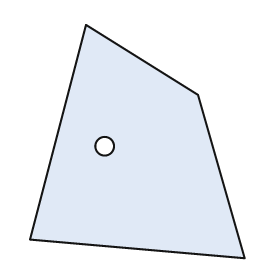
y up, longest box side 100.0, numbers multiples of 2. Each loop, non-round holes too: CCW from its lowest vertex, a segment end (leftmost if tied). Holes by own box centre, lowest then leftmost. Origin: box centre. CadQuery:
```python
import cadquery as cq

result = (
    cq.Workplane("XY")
    .moveTo(46.0, -50.0)
    .lineTo(26.0, 20.0)
    .lineTo(-22.0, 50.0)
    .lineTo(-46.0, -42.0)
    .close()
    .moveTo(-14.0, -2.0)
    .circle(4.0)
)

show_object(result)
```